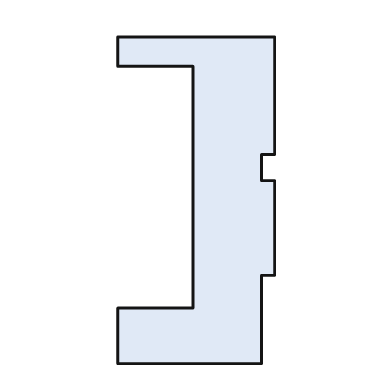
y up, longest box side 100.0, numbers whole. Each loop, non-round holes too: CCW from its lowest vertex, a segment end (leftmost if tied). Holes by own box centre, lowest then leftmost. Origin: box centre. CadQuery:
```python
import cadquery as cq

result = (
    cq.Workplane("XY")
    .moveTo(-24.0, -50.0)
    .lineTo(20.0, -50.0)
    .lineTo(20.0, -23.0)
    .lineTo(24.0, -23.0)
    .lineTo(24.0, 6.0)
    .lineTo(20.0, 6.0)
    .lineTo(20.0, 14.0)
    .lineTo(24.0, 14.0)
    .lineTo(24.0, 50.0)
    .lineTo(-24.0, 50.0)
    .lineTo(-24.0, 41.0)
    .lineTo(-1.0, 41.0)
    .lineTo(-1.0, -33.0)
    .lineTo(-24.0, -33.0)
    .close()
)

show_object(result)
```